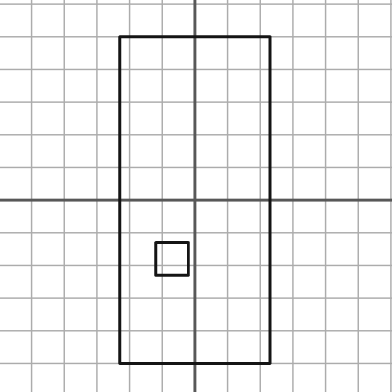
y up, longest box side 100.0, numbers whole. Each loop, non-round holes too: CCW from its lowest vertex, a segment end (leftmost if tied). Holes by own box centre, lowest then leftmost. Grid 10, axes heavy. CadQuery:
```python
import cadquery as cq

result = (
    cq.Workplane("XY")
    .moveTo(-23.0, -50.0)
    .lineTo(23.0, -50.0)
    .lineTo(23.0, 50.0)
    .lineTo(-23.0, 50.0)
    .close()
    .moveTo(-12.0, -23.0)
    .lineTo(-2.0, -23.0)
    .lineTo(-2.0, -13.0)
    .lineTo(-12.0, -13.0)
    .close()
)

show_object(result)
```